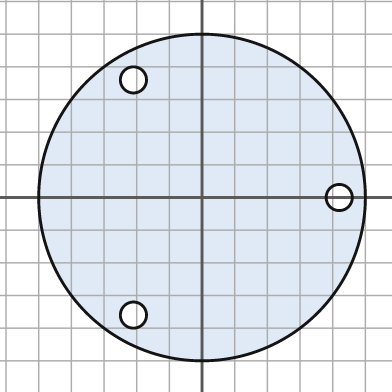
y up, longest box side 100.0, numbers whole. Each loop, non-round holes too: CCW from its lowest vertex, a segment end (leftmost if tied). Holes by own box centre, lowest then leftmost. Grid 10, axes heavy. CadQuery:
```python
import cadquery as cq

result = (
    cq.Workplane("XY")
    .moveTo(0.0, 0.0)
    .circle(50.0)
    .moveTo(-21.0, -36.0)
    .circle(4.0)
    .moveTo(42.0, 0.0)
    .circle(4.0)
    .moveTo(-21.0, 36.0)
    .circle(4.0)
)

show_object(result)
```